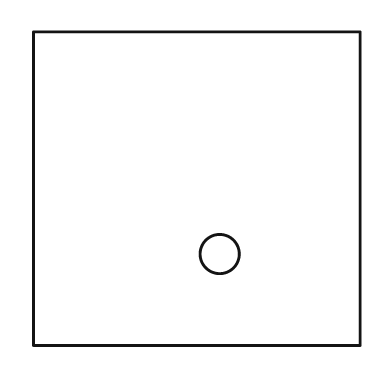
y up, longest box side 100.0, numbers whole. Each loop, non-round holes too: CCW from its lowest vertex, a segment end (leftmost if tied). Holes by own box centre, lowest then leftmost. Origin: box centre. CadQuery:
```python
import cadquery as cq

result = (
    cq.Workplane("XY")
    .moveTo(-50.0, -48.0)
    .lineTo(50.0, -48.0)
    .lineTo(50.0, 48.0)
    .lineTo(-50.0, 48.0)
    .close()
    .moveTo(7.0, -20.0)
    .circle(6.0)
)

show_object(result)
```